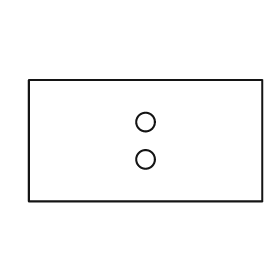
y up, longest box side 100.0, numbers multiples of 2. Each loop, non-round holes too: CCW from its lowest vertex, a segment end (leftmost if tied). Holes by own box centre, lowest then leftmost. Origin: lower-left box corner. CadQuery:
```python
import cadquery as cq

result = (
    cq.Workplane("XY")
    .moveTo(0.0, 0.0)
    .lineTo(100.0, 0.0)
    .lineTo(100.0, 52.0)
    .lineTo(0.0, 52.0)
    .close()
    .moveTo(50.0, 18.0)
    .circle(4.0)
    .moveTo(50.0, 34.0)
    .circle(4.0)
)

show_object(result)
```